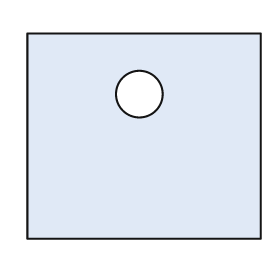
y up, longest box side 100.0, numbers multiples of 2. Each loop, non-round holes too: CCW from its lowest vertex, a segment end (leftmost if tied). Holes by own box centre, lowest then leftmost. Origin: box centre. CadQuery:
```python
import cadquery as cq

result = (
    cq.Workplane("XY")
    .moveTo(-50.0, -44.0)
    .lineTo(50.0, -44.0)
    .lineTo(50.0, 44.0)
    .lineTo(-50.0, 44.0)
    .close()
    .moveTo(-2.0, 18.0)
    .circle(10.0)
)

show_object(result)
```